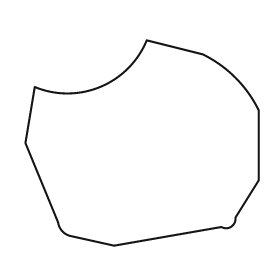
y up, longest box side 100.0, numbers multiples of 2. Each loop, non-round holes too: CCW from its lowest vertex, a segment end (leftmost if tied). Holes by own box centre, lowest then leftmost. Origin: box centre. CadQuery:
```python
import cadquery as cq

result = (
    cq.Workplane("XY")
    .moveTo(-12.0, -44.0)
    .lineTo(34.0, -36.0)
    .threePointArc((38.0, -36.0), (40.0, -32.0))
    .lineTo(50.0, -16.0)
    .lineTo(50.0, 14.0)
    .threePointArc((40.0, 28.0), (26.0, 38.0))
    .lineTo(2.0, 44.0)
    .threePointArc((-18.0, 24.0), (-46.0, 24.0))
    .lineTo(-50.0, 0.0)
    .lineTo(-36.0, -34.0)
    .threePointArc((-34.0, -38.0), (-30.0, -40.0))
    .close()
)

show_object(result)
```